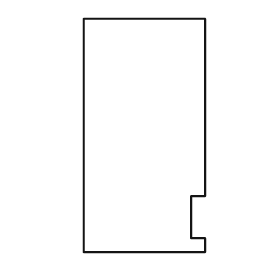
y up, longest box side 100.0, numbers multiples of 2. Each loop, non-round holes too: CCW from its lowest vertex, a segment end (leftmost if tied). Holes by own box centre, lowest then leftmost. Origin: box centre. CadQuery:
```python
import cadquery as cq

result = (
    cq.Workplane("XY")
    .moveTo(-26.0, -50.0)
    .lineTo(26.0, -50.0)
    .lineTo(26.0, -44.0)
    .lineTo(20.0, -44.0)
    .lineTo(20.0, -26.0)
    .lineTo(26.0, -26.0)
    .lineTo(26.0, 50.0)
    .lineTo(-26.0, 50.0)
    .close()
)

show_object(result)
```